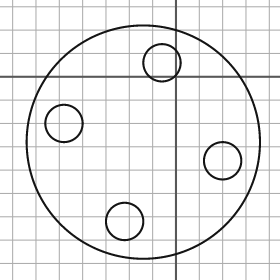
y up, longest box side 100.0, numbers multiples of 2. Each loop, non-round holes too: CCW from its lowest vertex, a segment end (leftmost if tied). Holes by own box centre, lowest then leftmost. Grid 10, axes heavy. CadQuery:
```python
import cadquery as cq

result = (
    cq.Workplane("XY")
    .moveTo(-14.0, -28.0)
    .circle(50.0)
    .moveTo(-22.0, -62.0)
    .circle(8.0)
    .moveTo(20.0, -36.0)
    .circle(8.0)
    .moveTo(-48.0, -20.0)
    .circle(8.0)
    .moveTo(-6.0, 6.0)
    .circle(8.0)
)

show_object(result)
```